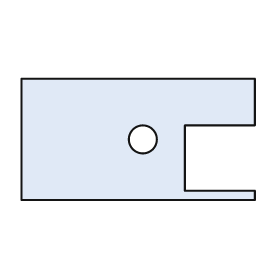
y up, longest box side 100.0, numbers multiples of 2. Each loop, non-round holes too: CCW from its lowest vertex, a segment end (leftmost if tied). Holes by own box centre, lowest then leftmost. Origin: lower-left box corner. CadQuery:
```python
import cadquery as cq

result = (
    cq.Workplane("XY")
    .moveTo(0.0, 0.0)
    .lineTo(100.0, 0.0)
    .lineTo(100.0, 4.0)
    .lineTo(70.0, 4.0)
    .lineTo(70.0, 32.0)
    .lineTo(100.0, 32.0)
    .lineTo(100.0, 52.0)
    .lineTo(0.0, 52.0)
    .close()
    .moveTo(52.0, 26.0)
    .circle(6.0)
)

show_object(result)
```